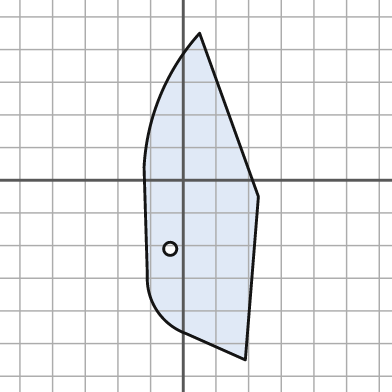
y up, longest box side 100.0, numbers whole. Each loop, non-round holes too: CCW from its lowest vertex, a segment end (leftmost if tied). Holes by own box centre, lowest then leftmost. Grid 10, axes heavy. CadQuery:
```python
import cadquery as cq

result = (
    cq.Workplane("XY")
    .moveTo(19.0, -55.0)
    .lineTo(23.0, -5.0)
    .lineTo(5.0, 45.0)
    .threePointArc((-7.0, 26.0), (-12.0, 4.0))
    .lineTo(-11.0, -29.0)
    .threePointArc((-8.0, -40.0), (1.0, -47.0))
    .close()
    .moveTo(-4.0, -21.0)
    .circle(2.0)
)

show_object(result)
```